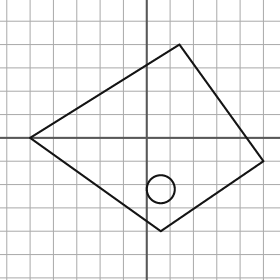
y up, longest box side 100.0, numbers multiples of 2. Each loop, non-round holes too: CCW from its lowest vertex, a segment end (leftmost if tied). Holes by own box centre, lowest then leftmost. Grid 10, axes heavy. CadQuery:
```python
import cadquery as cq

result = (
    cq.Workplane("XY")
    .moveTo(6.0, -40.0)
    .lineTo(50.0, -10.0)
    .lineTo(14.0, 40.0)
    .lineTo(-50.0, 0.0)
    .close()
    .moveTo(6.0, -22.0)
    .circle(6.0)
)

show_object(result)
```